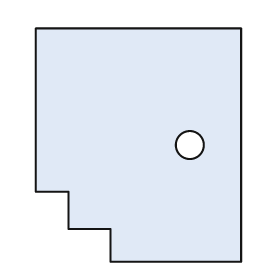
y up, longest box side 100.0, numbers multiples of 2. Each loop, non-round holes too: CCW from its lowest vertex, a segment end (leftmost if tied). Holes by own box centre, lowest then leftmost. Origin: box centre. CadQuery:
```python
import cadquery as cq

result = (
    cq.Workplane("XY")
    .moveTo(-12.0, -50.0)
    .lineTo(44.0, -50.0)
    .lineTo(44.0, 50.0)
    .lineTo(-44.0, 50.0)
    .lineTo(-44.0, -20.0)
    .lineTo(-30.0, -20.0)
    .lineTo(-30.0, -36.0)
    .lineTo(-12.0, -36.0)
    .close()
    .moveTo(22.0, 0.0)
    .circle(6.0)
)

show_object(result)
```